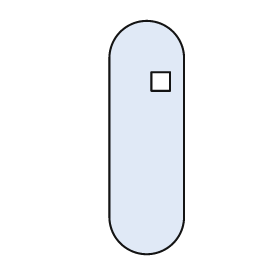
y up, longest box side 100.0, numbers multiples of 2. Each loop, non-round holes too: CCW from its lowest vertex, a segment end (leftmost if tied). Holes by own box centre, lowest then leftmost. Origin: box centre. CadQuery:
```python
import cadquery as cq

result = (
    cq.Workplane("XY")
    .moveTo(-16.0, -34.0)
    .threePointArc((0.0, -50.0), (16.0, -34.0))
    .lineTo(16.0, 34.0)
    .threePointArc((0.0, 50.0), (-16.0, 34.0))
    .close()
    .moveTo(2.0, 20.0)
    .lineTo(10.0, 20.0)
    .lineTo(10.0, 28.0)
    .lineTo(2.0, 28.0)
    .close()
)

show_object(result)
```